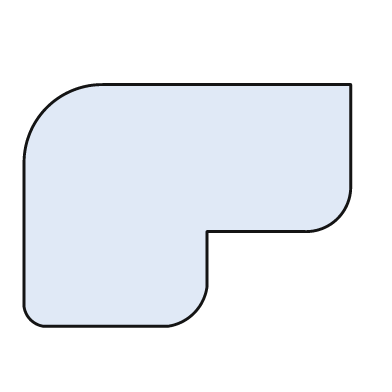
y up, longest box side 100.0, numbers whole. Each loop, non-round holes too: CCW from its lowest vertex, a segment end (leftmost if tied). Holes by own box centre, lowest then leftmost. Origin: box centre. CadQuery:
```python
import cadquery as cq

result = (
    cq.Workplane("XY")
    .moveTo(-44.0, -37.0)
    .lineTo(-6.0, -37.0)
    .threePointArc((2.0, -33.0), (6.0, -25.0))
    .lineTo(6.0, -8.0)
    .lineTo(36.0, -8.0)
    .threePointArc((46.0, -4.0), (50.0, 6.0))
    .lineTo(50.0, 37.0)
    .lineTo(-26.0, 37.0)
    .threePointArc((-43.0, 30.0), (-50.0, 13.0))
    .lineTo(-50.0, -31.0)
    .threePointArc((-48.0, -35.0), (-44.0, -37.0))
    .close()
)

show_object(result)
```